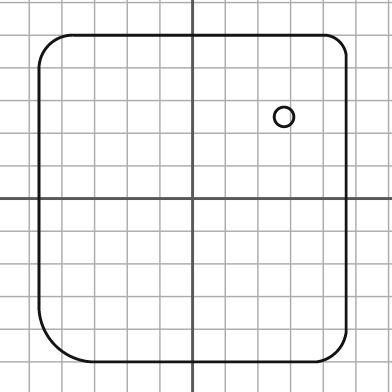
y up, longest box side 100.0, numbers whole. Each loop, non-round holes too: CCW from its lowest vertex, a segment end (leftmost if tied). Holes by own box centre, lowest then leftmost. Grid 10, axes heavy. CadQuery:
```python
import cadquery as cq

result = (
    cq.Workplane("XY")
    .moveTo(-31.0, -50.0)
    .lineTo(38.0, -50.0)
    .threePointArc((44.0, -47.0), (47.0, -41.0))
    .lineTo(47.0, 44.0)
    .threePointArc((45.0, 48.0), (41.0, 50.0))
    .lineTo(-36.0, 50.0)
    .threePointArc((-44.0, 47.0), (-47.0, 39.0))
    .lineTo(-47.0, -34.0)
    .threePointArc((-42.0, -45.0), (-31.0, -50.0))
    .close()
    .moveTo(28.0, 25.0)
    .circle(3.0)
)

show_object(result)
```